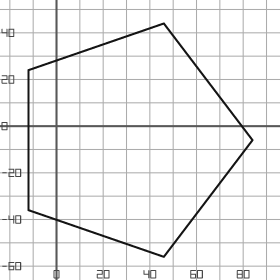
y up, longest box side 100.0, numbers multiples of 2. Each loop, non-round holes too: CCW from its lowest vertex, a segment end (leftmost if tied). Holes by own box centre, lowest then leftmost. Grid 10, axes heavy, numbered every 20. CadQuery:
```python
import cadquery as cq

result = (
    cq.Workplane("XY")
    .moveTo(46.0, -56.0)
    .lineTo(84.0, -6.0)
    .lineTo(46.0, 44.0)
    .lineTo(-12.0, 24.0)
    .lineTo(-12.0, -36.0)
    .close()
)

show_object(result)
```